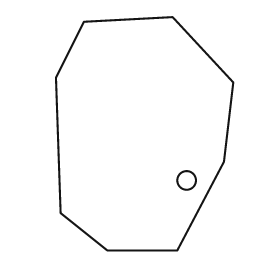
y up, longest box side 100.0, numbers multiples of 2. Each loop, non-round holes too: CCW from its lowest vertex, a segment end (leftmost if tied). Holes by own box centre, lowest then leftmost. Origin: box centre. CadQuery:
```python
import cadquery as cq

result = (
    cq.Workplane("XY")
    .moveTo(-16.0, -50.0)
    .lineTo(14.0, -50.0)
    .lineTo(34.0, -12.0)
    .lineTo(38.0, 22.0)
    .lineTo(12.0, 50.0)
    .lineTo(-26.0, 48.0)
    .lineTo(-38.0, 24.0)
    .lineTo(-36.0, -34.0)
    .close()
    .moveTo(18.0, -20.0)
    .circle(4.0)
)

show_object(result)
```